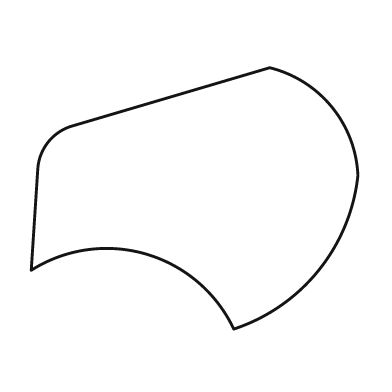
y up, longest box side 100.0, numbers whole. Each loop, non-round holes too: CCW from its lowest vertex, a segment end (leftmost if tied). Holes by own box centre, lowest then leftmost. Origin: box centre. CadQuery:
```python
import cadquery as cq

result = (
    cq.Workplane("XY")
    .moveTo(12.0, -40.0)
    .threePointArc((38.0, -22.0), (50.0, 7.0))
    .threePointArc((42.0, 28.0), (23.0, 40.0))
    .lineTo(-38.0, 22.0)
    .threePointArc((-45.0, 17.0), (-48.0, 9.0))
    .lineTo(-50.0, -22.0)
    .threePointArc((-15.0, -17.0), (12.0, -40.0))
    .close()
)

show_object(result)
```